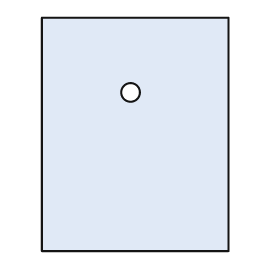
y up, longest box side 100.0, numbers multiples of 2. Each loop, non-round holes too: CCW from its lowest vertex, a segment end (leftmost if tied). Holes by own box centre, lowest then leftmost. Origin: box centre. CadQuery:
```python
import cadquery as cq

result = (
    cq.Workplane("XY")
    .moveTo(-40.0, -50.0)
    .lineTo(40.0, -50.0)
    .lineTo(40.0, 50.0)
    .lineTo(-40.0, 50.0)
    .close()
    .moveTo(-2.0, 18.0)
    .circle(4.0)
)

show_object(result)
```